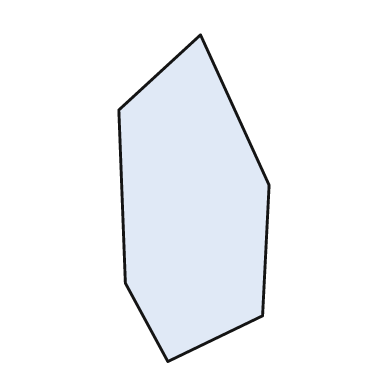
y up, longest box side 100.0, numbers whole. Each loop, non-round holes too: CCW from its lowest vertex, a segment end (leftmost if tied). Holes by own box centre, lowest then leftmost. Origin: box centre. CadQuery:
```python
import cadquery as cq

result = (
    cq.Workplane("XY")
    .moveTo(-8.0, -50.0)
    .lineTo(21.0, -36.0)
    .lineTo(23.0, 4.0)
    .lineTo(2.0, 50.0)
    .lineTo(-23.0, 27.0)
    .lineTo(-21.0, -26.0)
    .close()
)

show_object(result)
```